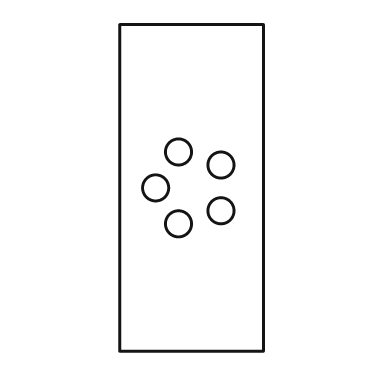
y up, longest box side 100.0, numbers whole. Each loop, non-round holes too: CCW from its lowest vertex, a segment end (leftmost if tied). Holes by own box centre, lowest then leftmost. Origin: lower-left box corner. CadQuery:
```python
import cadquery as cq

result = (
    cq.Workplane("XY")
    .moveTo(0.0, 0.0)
    .lineTo(44.0, 0.0)
    .lineTo(44.0, 100.0)
    .lineTo(0.0, 100.0)
    .close()
    .moveTo(18.0, 39.0)
    .circle(4.0)
    .moveTo(31.0, 43.0)
    .circle(4.0)
    .moveTo(11.0, 50.0)
    .circle(4.0)
    .moveTo(31.0, 57.0)
    .circle(4.0)
    .moveTo(18.0, 61.0)
    .circle(4.0)
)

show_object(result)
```